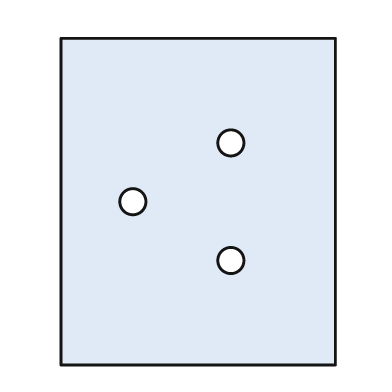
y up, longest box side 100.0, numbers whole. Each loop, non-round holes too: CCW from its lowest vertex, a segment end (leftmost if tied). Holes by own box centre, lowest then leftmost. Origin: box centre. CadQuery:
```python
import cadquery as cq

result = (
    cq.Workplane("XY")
    .moveTo(-42.0, -50.0)
    .lineTo(42.0, -50.0)
    .lineTo(42.0, 50.0)
    .lineTo(-42.0, 50.0)
    .close()
    .moveTo(10.0, -18.0)
    .circle(4.0)
    .moveTo(-20.0, 0.0)
    .circle(4.0)
    .moveTo(10.0, 18.0)
    .circle(4.0)
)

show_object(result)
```